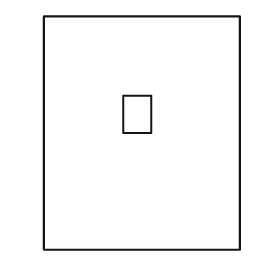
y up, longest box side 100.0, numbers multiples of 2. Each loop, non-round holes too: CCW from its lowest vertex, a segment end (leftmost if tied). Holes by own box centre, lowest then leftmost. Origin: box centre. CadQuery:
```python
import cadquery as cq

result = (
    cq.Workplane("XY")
    .moveTo(-42.0, -50.0)
    .lineTo(42.0, -50.0)
    .lineTo(42.0, 50.0)
    .lineTo(-42.0, 50.0)
    .close()
    .moveTo(-8.0, 0.0)
    .lineTo(4.0, 0.0)
    .lineTo(4.0, 16.0)
    .lineTo(-8.0, 16.0)
    .close()
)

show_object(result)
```